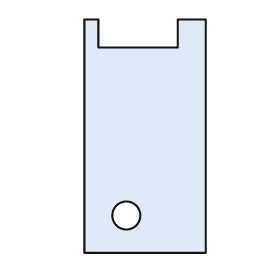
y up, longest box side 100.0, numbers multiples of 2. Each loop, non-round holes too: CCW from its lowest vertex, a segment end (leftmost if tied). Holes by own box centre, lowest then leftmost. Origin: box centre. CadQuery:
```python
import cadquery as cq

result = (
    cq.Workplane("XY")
    .moveTo(-26.0, -50.0)
    .lineTo(26.0, -50.0)
    .lineTo(26.0, 50.0)
    .lineTo(14.0, 50.0)
    .lineTo(14.0, 38.0)
    .lineTo(-20.0, 38.0)
    .lineTo(-20.0, 50.0)
    .lineTo(-26.0, 50.0)
    .close()
    .moveTo(-8.0, -34.0)
    .circle(6.0)
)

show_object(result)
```